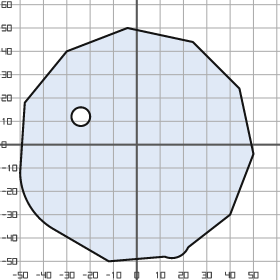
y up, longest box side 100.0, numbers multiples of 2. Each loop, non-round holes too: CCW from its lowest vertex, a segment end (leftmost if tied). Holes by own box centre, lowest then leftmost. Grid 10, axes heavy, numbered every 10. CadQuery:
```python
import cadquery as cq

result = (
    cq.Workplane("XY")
    .moveTo(-12.0, -50.0)
    .lineTo(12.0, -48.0)
    .threePointArc((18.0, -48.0), (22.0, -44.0))
    .lineTo(40.0, -30.0)
    .lineTo(50.0, -4.0)
    .lineTo(44.0, 24.0)
    .lineTo(24.0, 44.0)
    .lineTo(-4.0, 50.0)
    .lineTo(-30.0, 40.0)
    .lineTo(-48.0, 18.0)
    .lineTo(-50.0, -12.0)
    .threePointArc((-46.0, -26.0), (-36.0, -36.0))
    .close()
    .moveTo(-24.0, 12.0)
    .circle(4.0)
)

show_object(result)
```